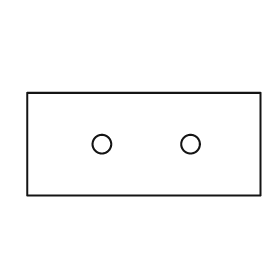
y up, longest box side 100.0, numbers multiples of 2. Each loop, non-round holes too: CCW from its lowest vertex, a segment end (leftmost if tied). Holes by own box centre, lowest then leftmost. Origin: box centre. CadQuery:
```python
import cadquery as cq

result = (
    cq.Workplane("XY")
    .moveTo(-50.0, -22.0)
    .lineTo(50.0, -22.0)
    .lineTo(50.0, 22.0)
    .lineTo(-50.0, 22.0)
    .close()
    .moveTo(-18.0, 0.0)
    .circle(4.0)
    .moveTo(20.0, 0.0)
    .circle(4.0)
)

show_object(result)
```